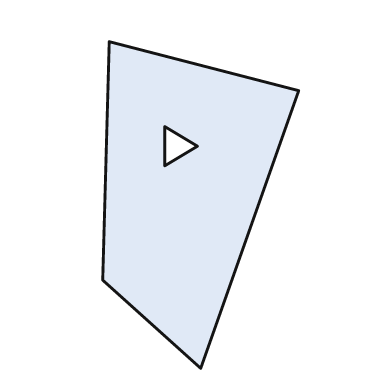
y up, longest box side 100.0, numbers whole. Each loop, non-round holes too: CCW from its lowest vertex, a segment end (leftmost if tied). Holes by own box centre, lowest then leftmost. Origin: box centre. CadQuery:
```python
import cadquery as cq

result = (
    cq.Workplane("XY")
    .moveTo(0.0, -50.0)
    .lineTo(30.0, 35.0)
    .lineTo(-28.0, 50.0)
    .lineTo(-30.0, -23.0)
    .close()
    .moveTo(-11.0, 12.0)
    .lineTo(-1.0, 18.0)
    .lineTo(-11.0, 24.0)
    .close()
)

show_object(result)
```